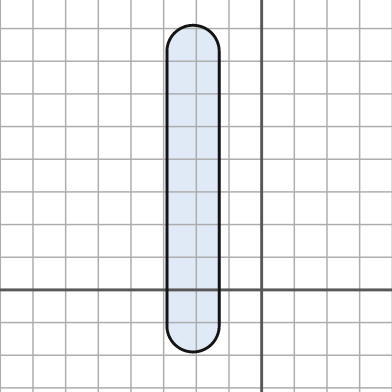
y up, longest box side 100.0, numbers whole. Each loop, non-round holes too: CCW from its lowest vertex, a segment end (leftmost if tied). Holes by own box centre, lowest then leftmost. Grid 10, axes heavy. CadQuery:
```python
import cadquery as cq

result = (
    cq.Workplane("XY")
    .moveTo(-29.0, -11.0)
    .threePointArc((-21.0, -19.0), (-13.0, -11.0))
    .lineTo(-13.0, 73.0)
    .threePointArc((-21.0, 81.0), (-29.0, 73.0))
    .close()
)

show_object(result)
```